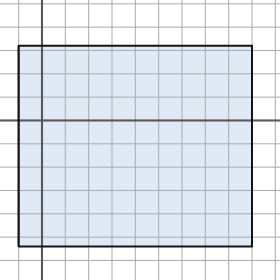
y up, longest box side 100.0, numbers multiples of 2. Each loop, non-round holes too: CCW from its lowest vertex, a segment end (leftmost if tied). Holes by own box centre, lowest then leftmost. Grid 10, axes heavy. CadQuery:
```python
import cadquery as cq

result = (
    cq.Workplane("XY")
    .moveTo(-10.0, -54.0)
    .lineTo(90.0, -54.0)
    .lineTo(90.0, 32.0)
    .lineTo(-10.0, 32.0)
    .close()
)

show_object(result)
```